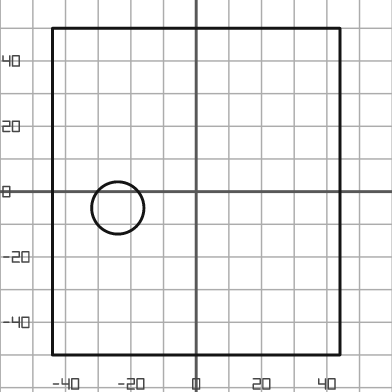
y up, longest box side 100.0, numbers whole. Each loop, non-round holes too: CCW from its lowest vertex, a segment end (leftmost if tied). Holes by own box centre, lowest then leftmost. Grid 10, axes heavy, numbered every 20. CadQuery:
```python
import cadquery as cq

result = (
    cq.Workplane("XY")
    .moveTo(-44.0, -50.0)
    .lineTo(44.0, -50.0)
    .lineTo(44.0, 50.0)
    .lineTo(-44.0, 50.0)
    .close()
    .moveTo(-24.0, -5.0)
    .circle(8.0)
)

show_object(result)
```